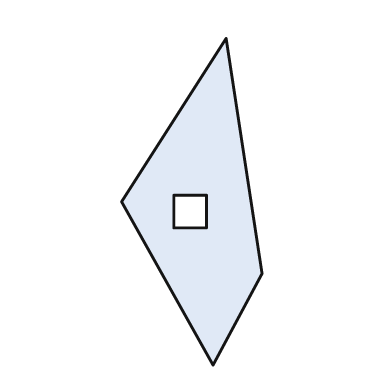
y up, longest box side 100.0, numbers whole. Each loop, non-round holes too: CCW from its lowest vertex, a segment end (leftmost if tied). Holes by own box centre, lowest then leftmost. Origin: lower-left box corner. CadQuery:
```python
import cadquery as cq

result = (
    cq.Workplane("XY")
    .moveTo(28.0, 0.0)
    .lineTo(43.0, 28.0)
    .lineTo(32.0, 100.0)
    .lineTo(0.0, 50.0)
    .close()
    .moveTo(16.0, 42.0)
    .lineTo(26.0, 42.0)
    .lineTo(26.0, 52.0)
    .lineTo(16.0, 52.0)
    .close()
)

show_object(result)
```